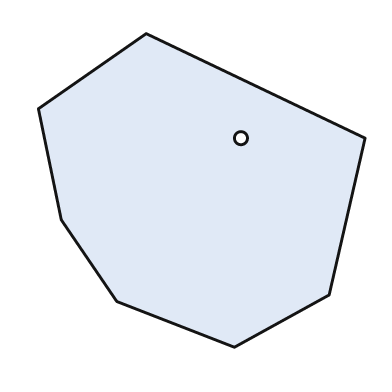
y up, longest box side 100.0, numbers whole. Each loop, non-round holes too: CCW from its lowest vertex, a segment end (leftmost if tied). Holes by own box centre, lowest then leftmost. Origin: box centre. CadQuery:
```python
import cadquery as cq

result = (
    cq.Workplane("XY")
    .moveTo(10.0, -48.0)
    .lineTo(39.0, -32.0)
    .lineTo(50.0, 16.0)
    .lineTo(-17.0, 48.0)
    .lineTo(-50.0, 25.0)
    .lineTo(-43.0, -9.0)
    .lineTo(-26.0, -34.0)
    .close()
    .moveTo(12.0, 16.0)
    .circle(2.0)
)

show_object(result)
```